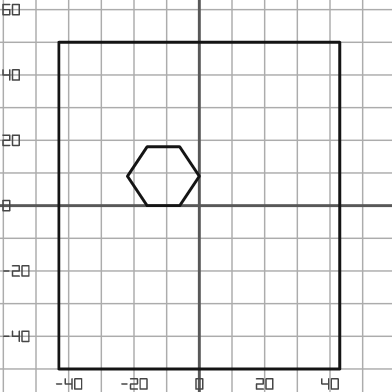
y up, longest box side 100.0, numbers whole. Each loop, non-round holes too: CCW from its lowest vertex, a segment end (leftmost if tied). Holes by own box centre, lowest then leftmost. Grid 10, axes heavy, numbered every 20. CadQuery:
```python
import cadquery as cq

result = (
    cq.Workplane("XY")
    .moveTo(-43.0, -50.0)
    .lineTo(43.0, -50.0)
    .lineTo(43.0, 50.0)
    .lineTo(-43.0, 50.0)
    .close()
    .moveTo(-16.0, 0.0)
    .lineTo(-6.0, 0.0)
    .lineTo(0.0, 9.0)
    .lineTo(-6.0, 18.0)
    .lineTo(-16.0, 18.0)
    .lineTo(-22.0, 9.0)
    .close()
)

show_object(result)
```